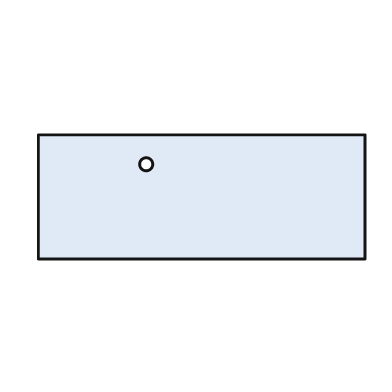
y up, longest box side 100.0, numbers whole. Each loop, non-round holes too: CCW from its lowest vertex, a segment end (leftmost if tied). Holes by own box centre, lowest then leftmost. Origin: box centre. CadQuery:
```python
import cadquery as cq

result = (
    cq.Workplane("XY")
    .moveTo(-50.0, -19.0)
    .lineTo(50.0, -19.0)
    .lineTo(50.0, 19.0)
    .lineTo(-50.0, 19.0)
    .close()
    .moveTo(-17.0, 10.0)
    .circle(2.0)
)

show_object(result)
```